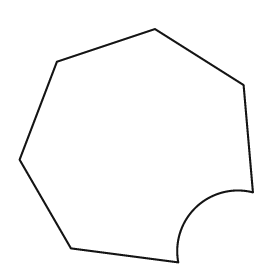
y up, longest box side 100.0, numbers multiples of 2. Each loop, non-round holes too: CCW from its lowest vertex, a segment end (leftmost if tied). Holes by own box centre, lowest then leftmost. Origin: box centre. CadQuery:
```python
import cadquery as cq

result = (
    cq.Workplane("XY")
    .moveTo(18.0, -50.0)
    .threePointArc((26.0, -26.0), (50.0, -20.0))
    .lineTo(46.0, 26.0)
    .lineTo(8.0, 50.0)
    .lineTo(-34.0, 36.0)
    .lineTo(-50.0, -6.0)
    .lineTo(-28.0, -44.0)
    .close()
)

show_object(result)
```